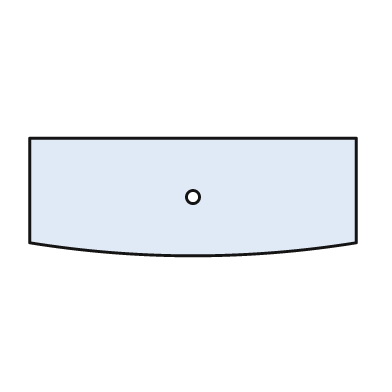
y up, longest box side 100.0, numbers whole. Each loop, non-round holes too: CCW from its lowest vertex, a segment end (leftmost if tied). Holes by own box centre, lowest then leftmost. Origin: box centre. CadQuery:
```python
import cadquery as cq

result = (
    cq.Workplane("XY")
    .moveTo(-50.0, -14.0)
    .threePointArc((0.0, -18.0), (50.0, -14.0))
    .lineTo(50.0, 18.0)
    .lineTo(-50.0, 18.0)
    .close()
    .moveTo(0.0, 0.0)
    .circle(2.0)
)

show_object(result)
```